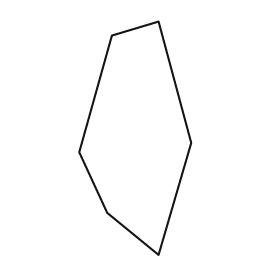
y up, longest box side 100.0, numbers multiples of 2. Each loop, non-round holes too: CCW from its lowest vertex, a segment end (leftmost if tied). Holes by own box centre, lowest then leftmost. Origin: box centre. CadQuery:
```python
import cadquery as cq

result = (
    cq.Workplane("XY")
    .moveTo(10.0, -50.0)
    .lineTo(24.0, -2.0)
    .lineTo(10.0, 50.0)
    .lineTo(-10.0, 44.0)
    .lineTo(-24.0, -6.0)
    .lineTo(-12.0, -32.0)
    .close()
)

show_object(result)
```